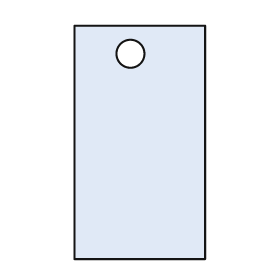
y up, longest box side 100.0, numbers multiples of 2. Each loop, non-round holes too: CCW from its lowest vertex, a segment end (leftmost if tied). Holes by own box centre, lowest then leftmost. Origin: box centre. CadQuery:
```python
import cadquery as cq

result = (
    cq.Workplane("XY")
    .moveTo(-28.0, -50.0)
    .lineTo(28.0, -50.0)
    .lineTo(28.0, 50.0)
    .lineTo(-28.0, 50.0)
    .close()
    .moveTo(-4.0, 38.0)
    .circle(6.0)
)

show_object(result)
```